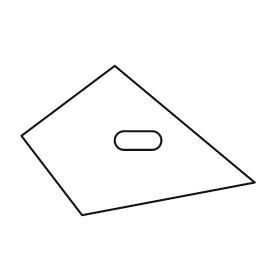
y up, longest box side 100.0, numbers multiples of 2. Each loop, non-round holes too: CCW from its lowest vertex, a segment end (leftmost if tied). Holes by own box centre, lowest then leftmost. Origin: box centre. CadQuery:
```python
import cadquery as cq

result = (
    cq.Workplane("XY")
    .moveTo(-24.0, -32.0)
    .lineTo(50.0, -18.0)
    .lineTo(-10.0, 32.0)
    .lineTo(-50.0, 2.0)
    .close()
    .moveTo(-6.0, -4.0)
    .lineTo(6.0, -4.0)
    .threePointArc((10.0, 0.0), (6.0, 4.0))
    .lineTo(-6.0, 4.0)
    .threePointArc((-10.0, 0.0), (-6.0, -4.0))
    .close()
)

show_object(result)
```